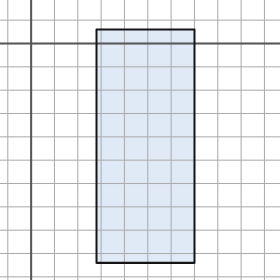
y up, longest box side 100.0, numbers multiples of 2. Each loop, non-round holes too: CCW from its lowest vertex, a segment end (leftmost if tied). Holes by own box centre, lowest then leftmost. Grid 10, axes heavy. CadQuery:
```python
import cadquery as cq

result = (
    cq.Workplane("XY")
    .moveTo(28.0, -94.0)
    .lineTo(70.0, -94.0)
    .lineTo(70.0, 6.0)
    .lineTo(28.0, 6.0)
    .close()
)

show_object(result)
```